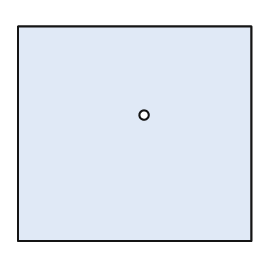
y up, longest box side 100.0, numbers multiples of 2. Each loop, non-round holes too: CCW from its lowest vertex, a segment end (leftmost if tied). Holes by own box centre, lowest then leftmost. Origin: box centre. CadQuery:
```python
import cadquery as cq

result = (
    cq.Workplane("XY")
    .moveTo(-50.0, -46.0)
    .lineTo(50.0, -46.0)
    .lineTo(50.0, 46.0)
    .lineTo(-50.0, 46.0)
    .close()
    .moveTo(4.0, 8.0)
    .circle(2.0)
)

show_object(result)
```